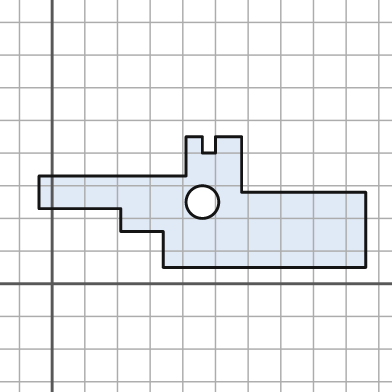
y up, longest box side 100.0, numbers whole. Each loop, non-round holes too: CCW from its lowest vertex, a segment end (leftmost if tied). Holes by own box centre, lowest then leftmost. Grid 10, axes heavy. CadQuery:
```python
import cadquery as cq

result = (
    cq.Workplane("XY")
    .moveTo(34.0, 5.0)
    .lineTo(96.0, 5.0)
    .lineTo(96.0, 28.0)
    .lineTo(58.0, 28.0)
    .lineTo(58.0, 45.0)
    .lineTo(50.0, 45.0)
    .lineTo(50.0, 40.0)
    .lineTo(46.0, 40.0)
    .lineTo(46.0, 45.0)
    .lineTo(41.0, 45.0)
    .lineTo(41.0, 33.0)
    .lineTo(-4.0, 33.0)
    .lineTo(-4.0, 23.0)
    .lineTo(21.0, 23.0)
    .lineTo(21.0, 16.0)
    .lineTo(34.0, 16.0)
    .close()
    .moveTo(46.0, 25.0)
    .circle(5.0)
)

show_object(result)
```